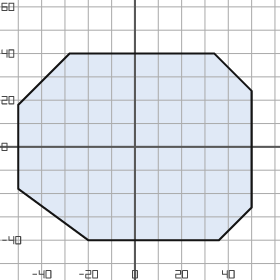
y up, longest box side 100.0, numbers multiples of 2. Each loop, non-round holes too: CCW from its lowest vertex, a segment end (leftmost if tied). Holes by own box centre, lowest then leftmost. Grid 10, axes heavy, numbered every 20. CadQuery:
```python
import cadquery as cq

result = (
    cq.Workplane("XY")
    .moveTo(-20.0, -40.0)
    .lineTo(36.0, -40.0)
    .lineTo(50.0, -26.0)
    .lineTo(50.0, 24.0)
    .lineTo(34.0, 40.0)
    .lineTo(-28.0, 40.0)
    .lineTo(-50.0, 18.0)
    .lineTo(-50.0, -18.0)
    .close()
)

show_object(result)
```